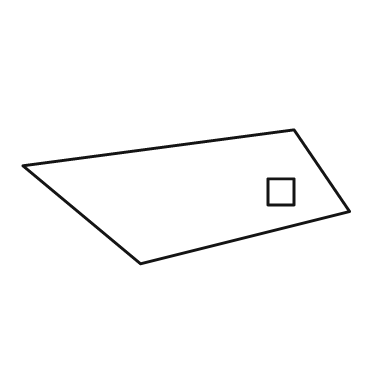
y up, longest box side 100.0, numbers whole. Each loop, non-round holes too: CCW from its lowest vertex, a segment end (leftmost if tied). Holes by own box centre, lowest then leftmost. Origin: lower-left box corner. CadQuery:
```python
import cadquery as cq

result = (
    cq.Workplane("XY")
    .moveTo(36.0, 0.0)
    .lineTo(100.0, 16.0)
    .lineTo(83.0, 41.0)
    .lineTo(0.0, 30.0)
    .close()
    .moveTo(75.0, 18.0)
    .lineTo(83.0, 18.0)
    .lineTo(83.0, 26.0)
    .lineTo(75.0, 26.0)
    .close()
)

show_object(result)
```